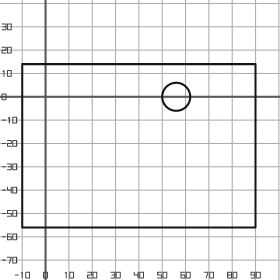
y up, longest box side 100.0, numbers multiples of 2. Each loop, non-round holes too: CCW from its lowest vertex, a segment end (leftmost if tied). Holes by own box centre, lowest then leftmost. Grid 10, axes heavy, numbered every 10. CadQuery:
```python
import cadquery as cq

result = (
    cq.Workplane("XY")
    .moveTo(-10.0, -56.0)
    .lineTo(90.0, -56.0)
    .lineTo(90.0, 14.0)
    .lineTo(-10.0, 14.0)
    .close()
    .moveTo(56.0, 0.0)
    .circle(6.0)
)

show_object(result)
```